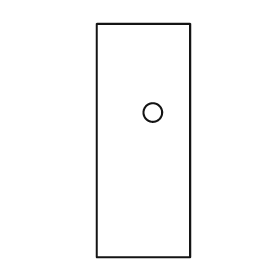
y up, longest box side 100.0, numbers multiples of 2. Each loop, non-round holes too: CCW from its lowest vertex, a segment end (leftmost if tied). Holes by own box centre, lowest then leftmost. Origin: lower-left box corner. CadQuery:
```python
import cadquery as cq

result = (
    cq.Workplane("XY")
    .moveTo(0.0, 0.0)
    .lineTo(40.0, 0.0)
    .lineTo(40.0, 100.0)
    .lineTo(0.0, 100.0)
    .close()
    .moveTo(24.0, 62.0)
    .circle(4.0)
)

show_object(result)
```